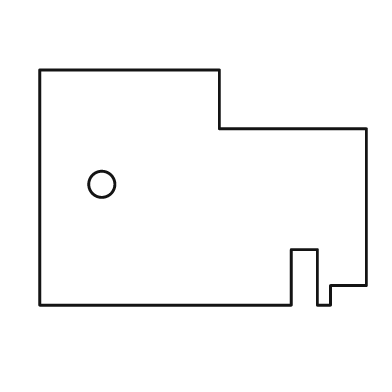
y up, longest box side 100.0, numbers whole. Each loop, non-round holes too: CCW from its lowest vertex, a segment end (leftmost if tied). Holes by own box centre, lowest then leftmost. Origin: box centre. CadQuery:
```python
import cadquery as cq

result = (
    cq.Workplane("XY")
    .moveTo(-50.0, -36.0)
    .lineTo(27.0, -36.0)
    .lineTo(27.0, -19.0)
    .lineTo(35.0, -19.0)
    .lineTo(35.0, -36.0)
    .lineTo(39.0, -36.0)
    .lineTo(39.0, -30.0)
    .lineTo(50.0, -30.0)
    .lineTo(50.0, 18.0)
    .lineTo(5.0, 18.0)
    .lineTo(5.0, 36.0)
    .lineTo(-50.0, 36.0)
    .close()
    .moveTo(-31.0, 1.0)
    .circle(4.0)
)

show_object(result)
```